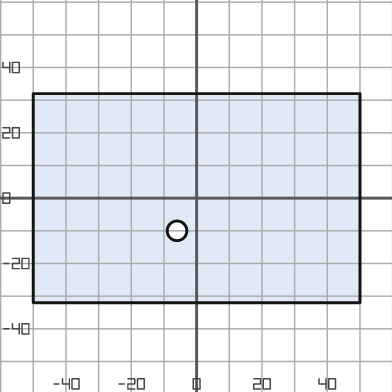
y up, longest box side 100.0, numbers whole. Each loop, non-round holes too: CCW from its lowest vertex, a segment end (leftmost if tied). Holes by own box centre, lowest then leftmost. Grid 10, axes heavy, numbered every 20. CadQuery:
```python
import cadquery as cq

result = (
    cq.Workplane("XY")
    .moveTo(-50.0, -32.0)
    .lineTo(50.0, -32.0)
    .lineTo(50.0, 32.0)
    .lineTo(-50.0, 32.0)
    .close()
    .moveTo(-6.0, -10.0)
    .circle(3.0)
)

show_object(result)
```